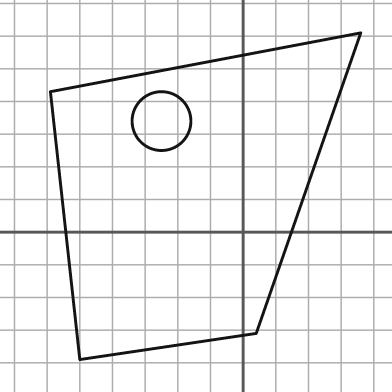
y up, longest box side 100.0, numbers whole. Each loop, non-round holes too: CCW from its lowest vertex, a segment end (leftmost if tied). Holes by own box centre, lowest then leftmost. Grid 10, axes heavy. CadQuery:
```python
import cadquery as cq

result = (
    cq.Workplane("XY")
    .moveTo(-50.0, -39.0)
    .lineTo(4.0, -31.0)
    .lineTo(36.0, 61.0)
    .lineTo(-59.0, 43.0)
    .close()
    .moveTo(-25.0, 34.0)
    .circle(9.0)
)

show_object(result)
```